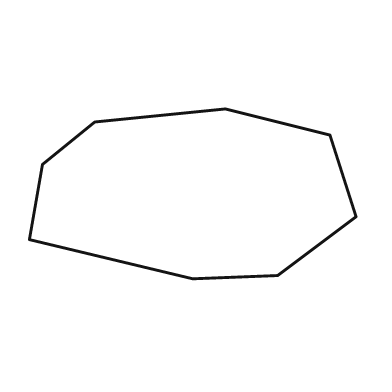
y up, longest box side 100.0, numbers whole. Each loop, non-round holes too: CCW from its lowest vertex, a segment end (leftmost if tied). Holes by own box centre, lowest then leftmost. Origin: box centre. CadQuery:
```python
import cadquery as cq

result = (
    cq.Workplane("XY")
    .moveTo(0.0, -26.0)
    .lineTo(26.0, -25.0)
    .lineTo(50.0, -7.0)
    .lineTo(42.0, 18.0)
    .lineTo(10.0, 26.0)
    .lineTo(-30.0, 22.0)
    .lineTo(-46.0, 9.0)
    .lineTo(-50.0, -14.0)
    .close()
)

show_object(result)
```